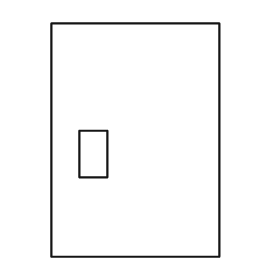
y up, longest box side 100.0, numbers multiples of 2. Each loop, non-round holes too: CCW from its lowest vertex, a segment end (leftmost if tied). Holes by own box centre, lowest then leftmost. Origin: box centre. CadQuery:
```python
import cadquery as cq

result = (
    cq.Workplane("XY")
    .moveTo(-36.0, -50.0)
    .lineTo(36.0, -50.0)
    .lineTo(36.0, 50.0)
    .lineTo(-36.0, 50.0)
    .close()
    .moveTo(-24.0, -16.0)
    .lineTo(-12.0, -16.0)
    .lineTo(-12.0, 4.0)
    .lineTo(-24.0, 4.0)
    .close()
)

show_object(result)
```